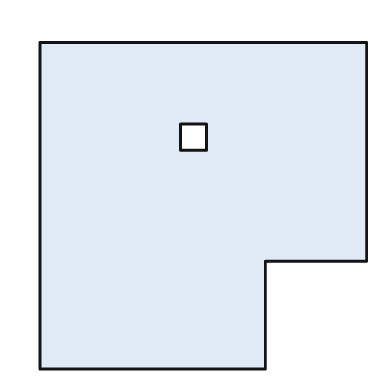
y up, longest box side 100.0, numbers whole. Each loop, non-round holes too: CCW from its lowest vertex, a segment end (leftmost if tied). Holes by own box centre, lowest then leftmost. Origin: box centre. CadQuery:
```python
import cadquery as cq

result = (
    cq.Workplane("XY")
    .moveTo(-50.0, -50.0)
    .lineTo(19.0, -50.0)
    .lineTo(19.0, -17.0)
    .lineTo(50.0, -17.0)
    .lineTo(50.0, 50.0)
    .lineTo(-50.0, 50.0)
    .close()
    .moveTo(-7.0, 17.0)
    .lineTo(1.0, 17.0)
    .lineTo(1.0, 25.0)
    .lineTo(-7.0, 25.0)
    .close()
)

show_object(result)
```